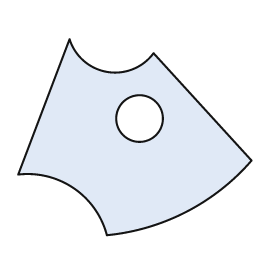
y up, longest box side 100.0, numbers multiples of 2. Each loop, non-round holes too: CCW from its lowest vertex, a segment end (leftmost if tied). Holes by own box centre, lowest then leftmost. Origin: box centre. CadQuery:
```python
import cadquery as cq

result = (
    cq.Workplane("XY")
    .moveTo(-12.0, -42.0)
    .threePointArc((22.0, -32.0), (50.0, -10.0))
    .lineTo(8.0, 36.0)
    .threePointArc((-12.0, 28.0), (-28.0, 42.0))
    .lineTo(-50.0, -16.0)
    .threePointArc((-26.0, -22.0), (-12.0, -42.0))
    .close()
    .moveTo(2.0, 8.0)
    .circle(10.0)
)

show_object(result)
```